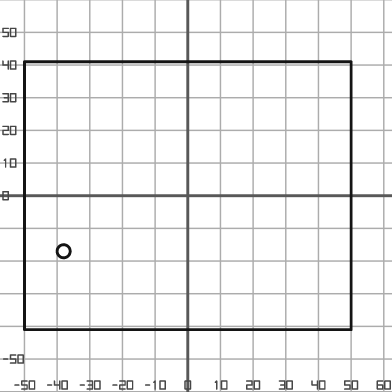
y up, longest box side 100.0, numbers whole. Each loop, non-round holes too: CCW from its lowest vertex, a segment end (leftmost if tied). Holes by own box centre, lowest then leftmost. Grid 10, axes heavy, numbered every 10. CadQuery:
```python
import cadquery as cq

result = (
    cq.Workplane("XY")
    .moveTo(-50.0, -41.0)
    .lineTo(50.0, -41.0)
    .lineTo(50.0, 41.0)
    .lineTo(-50.0, 41.0)
    .close()
    .moveTo(-38.0, -17.0)
    .circle(2.0)
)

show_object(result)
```